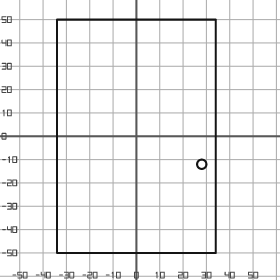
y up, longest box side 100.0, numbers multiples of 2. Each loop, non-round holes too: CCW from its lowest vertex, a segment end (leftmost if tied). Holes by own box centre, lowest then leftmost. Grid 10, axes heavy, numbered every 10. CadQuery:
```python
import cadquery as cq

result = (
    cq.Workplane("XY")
    .moveTo(-34.0, -50.0)
    .lineTo(34.0, -50.0)
    .lineTo(34.0, 50.0)
    .lineTo(-34.0, 50.0)
    .close()
    .moveTo(28.0, -12.0)
    .circle(2.0)
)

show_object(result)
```